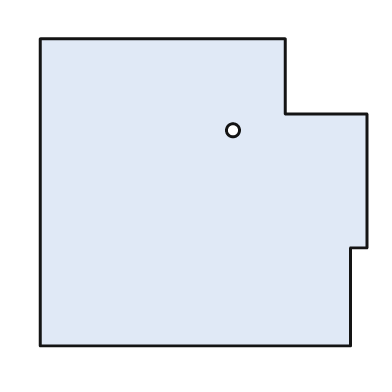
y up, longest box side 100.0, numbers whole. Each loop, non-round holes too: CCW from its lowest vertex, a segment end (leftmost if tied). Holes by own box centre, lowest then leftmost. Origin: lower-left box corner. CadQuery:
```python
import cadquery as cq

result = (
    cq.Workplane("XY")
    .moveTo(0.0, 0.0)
    .lineTo(95.0, 0.0)
    .lineTo(95.0, 30.0)
    .lineTo(100.0, 30.0)
    .lineTo(100.0, 71.0)
    .lineTo(75.0, 71.0)
    .lineTo(75.0, 94.0)
    .lineTo(0.0, 94.0)
    .close()
    .moveTo(59.0, 66.0)
    .circle(2.0)
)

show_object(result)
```